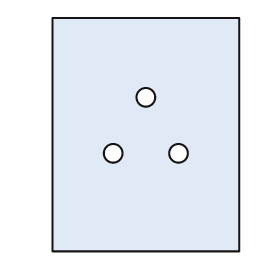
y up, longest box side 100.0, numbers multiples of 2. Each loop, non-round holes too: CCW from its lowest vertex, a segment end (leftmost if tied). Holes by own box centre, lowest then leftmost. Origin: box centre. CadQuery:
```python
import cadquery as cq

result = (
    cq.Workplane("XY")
    .moveTo(-40.0, -50.0)
    .lineTo(40.0, -50.0)
    .lineTo(40.0, 50.0)
    .lineTo(-40.0, 50.0)
    .close()
    .moveTo(-14.0, -8.0)
    .circle(4.0)
    .moveTo(14.0, -8.0)
    .circle(4.0)
    .moveTo(0.0, 16.0)
    .circle(4.0)
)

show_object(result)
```